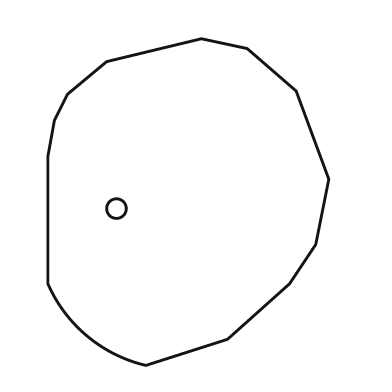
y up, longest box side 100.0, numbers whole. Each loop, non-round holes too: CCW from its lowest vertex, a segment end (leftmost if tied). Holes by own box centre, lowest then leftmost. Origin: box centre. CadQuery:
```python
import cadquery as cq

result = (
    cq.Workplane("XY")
    .moveTo(-13.0, -50.0)
    .lineTo(12.0, -42.0)
    .lineTo(31.0, -25.0)
    .lineTo(39.0, -13.0)
    .lineTo(43.0, 7.0)
    .lineTo(33.0, 34.0)
    .lineTo(18.0, 47.0)
    .lineTo(4.0, 50.0)
    .lineTo(-25.0, 43.0)
    .lineTo(-37.0, 33.0)
    .lineTo(-41.0, 25.0)
    .lineTo(-43.0, 14.0)
    .lineTo(-43.0, -25.0)
    .threePointArc((-31.0, -41.0), (-13.0, -50.0))
    .close()
    .moveTo(-22.0, -2.0)
    .circle(3.0)
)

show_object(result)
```